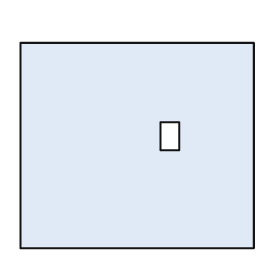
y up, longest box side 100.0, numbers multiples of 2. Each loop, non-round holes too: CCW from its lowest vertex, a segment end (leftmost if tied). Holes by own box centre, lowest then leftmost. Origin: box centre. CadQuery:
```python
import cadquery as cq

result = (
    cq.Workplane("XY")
    .moveTo(-50.0, -44.0)
    .lineTo(50.0, -44.0)
    .lineTo(50.0, 44.0)
    .lineTo(-50.0, 44.0)
    .close()
    .moveTo(10.0, -2.0)
    .lineTo(18.0, -2.0)
    .lineTo(18.0, 10.0)
    .lineTo(10.0, 10.0)
    .close()
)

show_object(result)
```